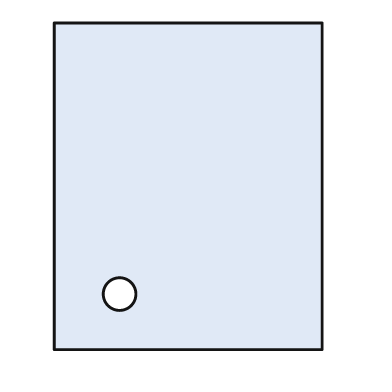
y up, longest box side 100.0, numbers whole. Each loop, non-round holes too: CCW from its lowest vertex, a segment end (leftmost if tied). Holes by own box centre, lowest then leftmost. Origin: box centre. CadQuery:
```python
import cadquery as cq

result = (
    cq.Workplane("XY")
    .moveTo(-41.0, -50.0)
    .lineTo(41.0, -50.0)
    .lineTo(41.0, 50.0)
    .lineTo(-41.0, 50.0)
    .close()
    .moveTo(-21.0, -33.0)
    .circle(5.0)
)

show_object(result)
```